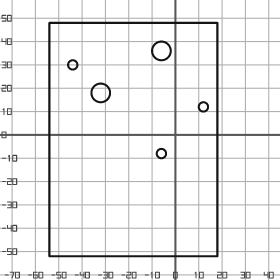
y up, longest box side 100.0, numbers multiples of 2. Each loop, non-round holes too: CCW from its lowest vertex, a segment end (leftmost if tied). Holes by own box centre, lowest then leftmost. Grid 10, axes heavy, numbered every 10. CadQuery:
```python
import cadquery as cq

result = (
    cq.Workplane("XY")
    .moveTo(-54.0, -52.0)
    .lineTo(18.0, -52.0)
    .lineTo(18.0, 48.0)
    .lineTo(-54.0, 48.0)
    .close()
    .moveTo(-6.0, -8.0)
    .circle(2.0)
    .moveTo(12.0, 12.0)
    .circle(2.0)
    .moveTo(-32.0, 18.0)
    .circle(4.0)
    .moveTo(-44.0, 30.0)
    .circle(2.0)
    .moveTo(-6.0, 36.0)
    .circle(4.0)
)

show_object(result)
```